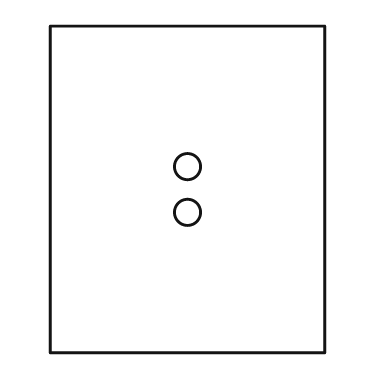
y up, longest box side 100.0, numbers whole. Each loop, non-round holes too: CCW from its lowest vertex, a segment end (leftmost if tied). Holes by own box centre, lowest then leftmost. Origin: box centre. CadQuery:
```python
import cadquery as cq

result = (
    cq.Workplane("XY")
    .moveTo(-42.0, -50.0)
    .lineTo(42.0, -50.0)
    .lineTo(42.0, 50.0)
    .lineTo(-42.0, 50.0)
    .close()
    .moveTo(0.0, -7.0)
    .circle(4.0)
    .moveTo(0.0, 7.0)
    .circle(4.0)
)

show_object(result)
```